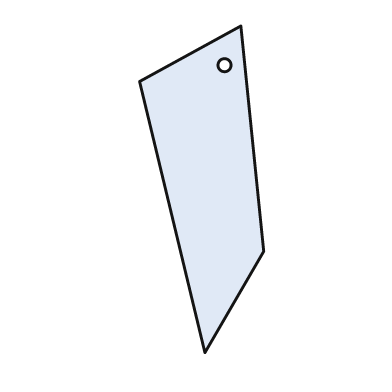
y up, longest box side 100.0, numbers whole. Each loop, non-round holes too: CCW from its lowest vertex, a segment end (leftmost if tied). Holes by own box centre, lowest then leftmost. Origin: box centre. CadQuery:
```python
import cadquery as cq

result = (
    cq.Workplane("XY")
    .moveTo(1.0, -50.0)
    .lineTo(19.0, -19.0)
    .lineTo(12.0, 50.0)
    .lineTo(-19.0, 33.0)
    .close()
    .moveTo(7.0, 38.0)
    .circle(2.0)
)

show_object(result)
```